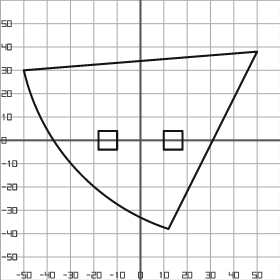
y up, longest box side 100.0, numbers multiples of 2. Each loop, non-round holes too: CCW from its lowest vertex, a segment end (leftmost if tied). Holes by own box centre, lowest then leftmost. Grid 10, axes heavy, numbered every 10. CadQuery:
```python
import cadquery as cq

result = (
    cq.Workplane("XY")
    .moveTo(12.0, -38.0)
    .lineTo(50.0, 38.0)
    .lineTo(-50.0, 30.0)
    .threePointArc((-28.0, -12.0), (12.0, -38.0))
    .close()
    .moveTo(-18.0, -4.0)
    .lineTo(-10.0, -4.0)
    .lineTo(-10.0, 4.0)
    .lineTo(-18.0, 4.0)
    .close()
    .moveTo(10.0, -4.0)
    .lineTo(18.0, -4.0)
    .lineTo(18.0, 4.0)
    .lineTo(10.0, 4.0)
    .close()
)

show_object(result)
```